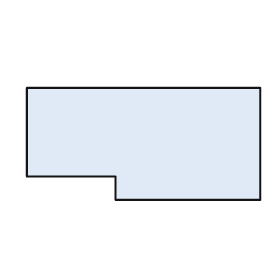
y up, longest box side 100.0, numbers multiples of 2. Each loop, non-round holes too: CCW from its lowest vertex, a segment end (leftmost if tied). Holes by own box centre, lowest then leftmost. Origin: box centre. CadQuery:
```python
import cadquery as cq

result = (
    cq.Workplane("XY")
    .moveTo(-12.0, -24.0)
    .lineTo(50.0, -24.0)
    .lineTo(50.0, 24.0)
    .lineTo(-50.0, 24.0)
    .lineTo(-50.0, -14.0)
    .lineTo(-12.0, -14.0)
    .close()
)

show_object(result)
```